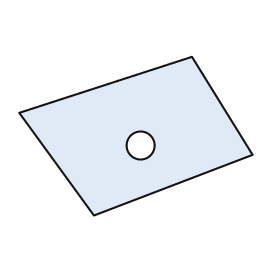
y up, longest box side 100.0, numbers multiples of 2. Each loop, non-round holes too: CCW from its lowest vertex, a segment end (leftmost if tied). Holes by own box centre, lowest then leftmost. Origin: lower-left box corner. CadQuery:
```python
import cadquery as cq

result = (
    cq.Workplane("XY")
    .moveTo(32.0, 0.0)
    .lineTo(100.0, 26.0)
    .lineTo(74.0, 68.0)
    .lineTo(0.0, 44.0)
    .close()
    .moveTo(52.0, 30.0)
    .circle(6.0)
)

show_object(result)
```